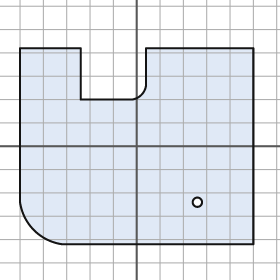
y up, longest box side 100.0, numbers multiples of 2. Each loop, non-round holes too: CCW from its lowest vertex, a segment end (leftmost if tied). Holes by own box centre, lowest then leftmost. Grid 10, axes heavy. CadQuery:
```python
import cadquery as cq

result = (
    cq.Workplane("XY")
    .moveTo(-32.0, -42.0)
    .lineTo(50.0, -42.0)
    .lineTo(50.0, 42.0)
    .lineTo(4.0, 42.0)
    .lineTo(4.0, 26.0)
    .threePointArc((2.0, 22.0), (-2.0, 20.0))
    .lineTo(-24.0, 20.0)
    .lineTo(-24.0, 42.0)
    .lineTo(-50.0, 42.0)
    .lineTo(-50.0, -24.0)
    .threePointArc((-44.0, -36.0), (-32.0, -42.0))
    .close()
    .moveTo(26.0, -24.0)
    .circle(2.0)
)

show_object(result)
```